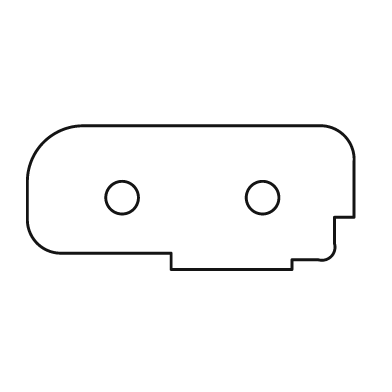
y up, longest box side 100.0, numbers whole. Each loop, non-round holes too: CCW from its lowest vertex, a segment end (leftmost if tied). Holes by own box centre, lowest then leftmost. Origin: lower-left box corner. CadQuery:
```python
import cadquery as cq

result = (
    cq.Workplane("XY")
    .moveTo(44.0, 0.0)
    .lineTo(81.0, 0.0)
    .lineTo(81.0, 3.0)
    .lineTo(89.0, 3.0)
    .threePointArc((93.0, 4.0), (94.0, 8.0))
    .lineTo(94.0, 16.0)
    .lineTo(100.0, 16.0)
    .lineTo(100.0, 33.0)
    .threePointArc((97.0, 41.0), (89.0, 44.0))
    .lineTo(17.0, 44.0)
    .threePointArc((5.0, 39.0), (0.0, 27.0))
    .lineTo(0.0, 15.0)
    .threePointArc((3.0, 8.0), (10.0, 5.0))
    .lineTo(44.0, 5.0)
    .close()
    .moveTo(29.0, 22.0)
    .circle(5.0)
    .moveTo(72.0, 22.0)
    .circle(5.0)
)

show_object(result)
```